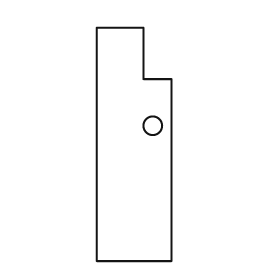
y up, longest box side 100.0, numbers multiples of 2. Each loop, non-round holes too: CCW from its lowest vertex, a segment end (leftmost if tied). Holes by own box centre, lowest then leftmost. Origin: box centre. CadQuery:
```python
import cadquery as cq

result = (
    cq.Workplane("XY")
    .moveTo(-16.0, -50.0)
    .lineTo(16.0, -50.0)
    .lineTo(16.0, 28.0)
    .lineTo(4.0, 28.0)
    .lineTo(4.0, 50.0)
    .lineTo(-16.0, 50.0)
    .close()
    .moveTo(8.0, 8.0)
    .circle(4.0)
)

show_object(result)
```